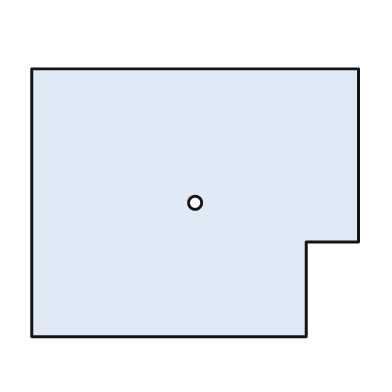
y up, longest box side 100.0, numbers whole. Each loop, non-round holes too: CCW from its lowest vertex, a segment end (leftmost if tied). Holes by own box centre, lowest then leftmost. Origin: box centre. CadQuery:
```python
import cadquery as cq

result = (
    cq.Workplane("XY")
    .moveTo(-50.0, -41.0)
    .lineTo(34.0, -41.0)
    .lineTo(34.0, -12.0)
    .lineTo(50.0, -12.0)
    .lineTo(50.0, 41.0)
    .lineTo(-50.0, 41.0)
    .close()
    .moveTo(0.0, 0.0)
    .circle(2.0)
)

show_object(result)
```